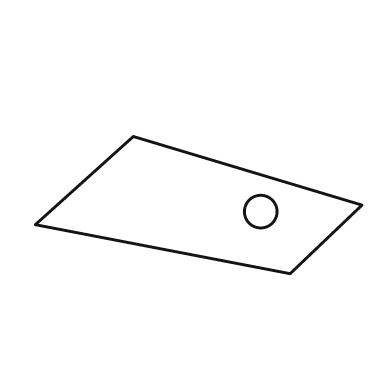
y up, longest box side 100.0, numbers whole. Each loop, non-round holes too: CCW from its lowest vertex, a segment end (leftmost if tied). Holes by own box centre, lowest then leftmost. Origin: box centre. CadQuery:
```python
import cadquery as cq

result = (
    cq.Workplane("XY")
    .moveTo(28.0, -21.0)
    .lineTo(50.0, 0.0)
    .lineTo(-20.0, 21.0)
    .lineTo(-50.0, -6.0)
    .close()
    .moveTo(19.0, -2.0)
    .circle(5.0)
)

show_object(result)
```